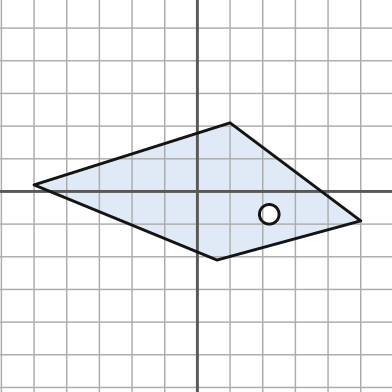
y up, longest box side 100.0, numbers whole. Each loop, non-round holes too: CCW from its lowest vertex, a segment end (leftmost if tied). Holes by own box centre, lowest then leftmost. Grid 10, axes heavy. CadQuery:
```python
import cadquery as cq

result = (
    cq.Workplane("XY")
    .moveTo(6.0, -21.0)
    .lineTo(50.0, -9.0)
    .lineTo(10.0, 21.0)
    .lineTo(-50.0, 2.0)
    .close()
    .moveTo(22.0, -7.0)
    .circle(3.0)
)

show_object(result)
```